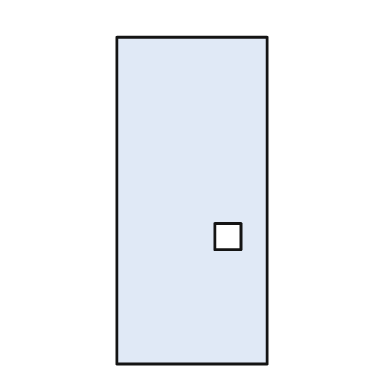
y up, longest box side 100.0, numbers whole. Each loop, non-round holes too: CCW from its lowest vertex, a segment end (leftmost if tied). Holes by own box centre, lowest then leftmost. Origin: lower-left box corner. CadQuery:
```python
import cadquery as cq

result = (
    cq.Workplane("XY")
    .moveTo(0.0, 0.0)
    .lineTo(46.0, 0.0)
    .lineTo(46.0, 100.0)
    .lineTo(0.0, 100.0)
    .close()
    .moveTo(30.0, 35.0)
    .lineTo(38.0, 35.0)
    .lineTo(38.0, 43.0)
    .lineTo(30.0, 43.0)
    .close()
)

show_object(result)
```